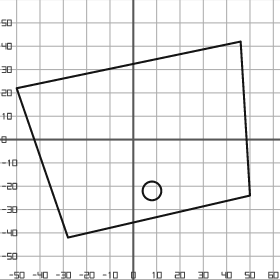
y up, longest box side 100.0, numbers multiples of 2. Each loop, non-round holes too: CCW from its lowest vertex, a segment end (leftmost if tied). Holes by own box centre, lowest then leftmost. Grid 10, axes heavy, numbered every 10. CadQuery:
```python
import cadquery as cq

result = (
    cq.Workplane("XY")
    .moveTo(-28.0, -42.0)
    .lineTo(50.0, -24.0)
    .lineTo(46.0, 42.0)
    .lineTo(-50.0, 22.0)
    .close()
    .moveTo(8.0, -22.0)
    .circle(4.0)
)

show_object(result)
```